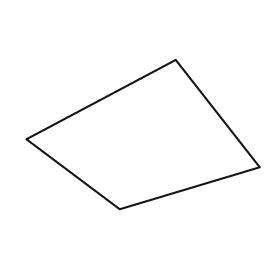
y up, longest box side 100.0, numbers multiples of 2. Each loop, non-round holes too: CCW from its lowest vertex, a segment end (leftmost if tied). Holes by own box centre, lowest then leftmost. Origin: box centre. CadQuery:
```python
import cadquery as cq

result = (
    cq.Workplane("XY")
    .moveTo(-10.0, -32.0)
    .lineTo(50.0, -14.0)
    .lineTo(14.0, 32.0)
    .lineTo(-50.0, -2.0)
    .close()
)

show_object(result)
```